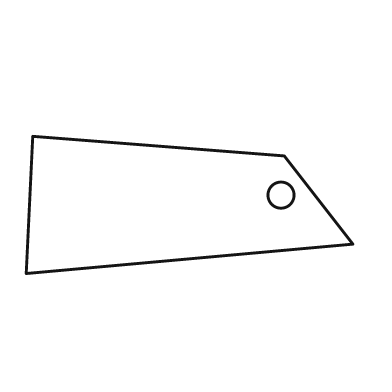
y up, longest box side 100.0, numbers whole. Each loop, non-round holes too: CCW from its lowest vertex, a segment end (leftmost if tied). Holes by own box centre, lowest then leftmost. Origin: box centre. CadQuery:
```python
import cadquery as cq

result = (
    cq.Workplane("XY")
    .moveTo(-50.0, -21.0)
    .lineTo(50.0, -12.0)
    .lineTo(29.0, 15.0)
    .lineTo(-48.0, 21.0)
    .close()
    .moveTo(28.0, 3.0)
    .circle(4.0)
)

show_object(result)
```